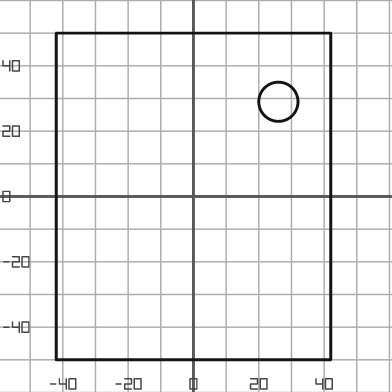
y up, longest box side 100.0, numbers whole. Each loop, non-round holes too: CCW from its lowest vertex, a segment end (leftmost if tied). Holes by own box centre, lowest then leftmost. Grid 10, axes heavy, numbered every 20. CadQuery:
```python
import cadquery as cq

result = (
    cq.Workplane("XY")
    .moveTo(-42.0, -50.0)
    .lineTo(42.0, -50.0)
    .lineTo(42.0, 50.0)
    .lineTo(-42.0, 50.0)
    .close()
    .moveTo(26.0, 29.0)
    .circle(6.0)
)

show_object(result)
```